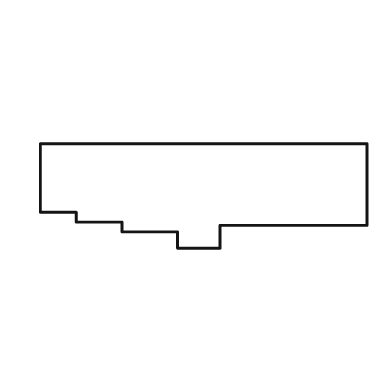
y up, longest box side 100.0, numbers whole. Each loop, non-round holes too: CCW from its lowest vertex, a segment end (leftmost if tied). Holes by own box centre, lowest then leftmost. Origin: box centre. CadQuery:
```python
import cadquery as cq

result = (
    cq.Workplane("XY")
    .moveTo(-8.0, -16.0)
    .lineTo(5.0, -16.0)
    .lineTo(5.0, -9.0)
    .lineTo(50.0, -9.0)
    .lineTo(50.0, 16.0)
    .lineTo(-50.0, 16.0)
    .lineTo(-50.0, -5.0)
    .lineTo(-39.0, -5.0)
    .lineTo(-39.0, -8.0)
    .lineTo(-25.0, -8.0)
    .lineTo(-25.0, -11.0)
    .lineTo(-8.0, -11.0)
    .close()
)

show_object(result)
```